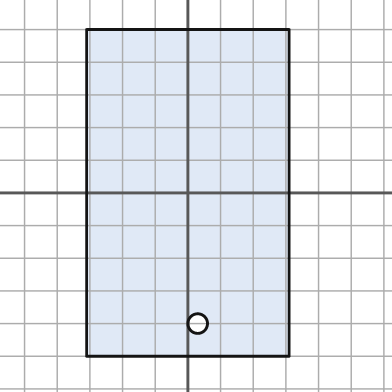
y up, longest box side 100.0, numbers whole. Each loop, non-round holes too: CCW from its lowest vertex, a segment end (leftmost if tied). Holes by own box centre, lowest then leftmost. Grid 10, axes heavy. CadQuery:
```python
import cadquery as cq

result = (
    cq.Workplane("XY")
    .moveTo(-31.0, -50.0)
    .lineTo(31.0, -50.0)
    .lineTo(31.0, 50.0)
    .lineTo(-31.0, 50.0)
    .close()
    .moveTo(3.0, -40.0)
    .circle(3.0)
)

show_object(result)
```